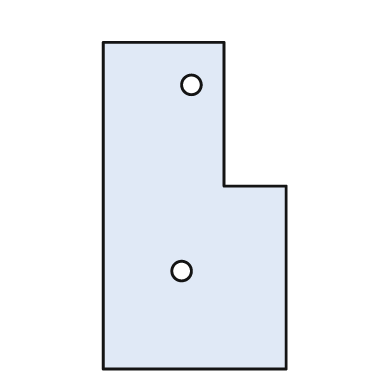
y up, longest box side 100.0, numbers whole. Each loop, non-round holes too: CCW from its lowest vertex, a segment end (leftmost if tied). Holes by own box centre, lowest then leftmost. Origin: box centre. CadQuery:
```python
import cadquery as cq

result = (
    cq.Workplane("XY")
    .moveTo(-28.0, -50.0)
    .lineTo(28.0, -50.0)
    .lineTo(28.0, 6.0)
    .lineTo(9.0, 6.0)
    .lineTo(9.0, 50.0)
    .lineTo(-28.0, 50.0)
    .close()
    .moveTo(-4.0, -20.0)
    .circle(3.0)
    .moveTo(-1.0, 37.0)
    .circle(3.0)
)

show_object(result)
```